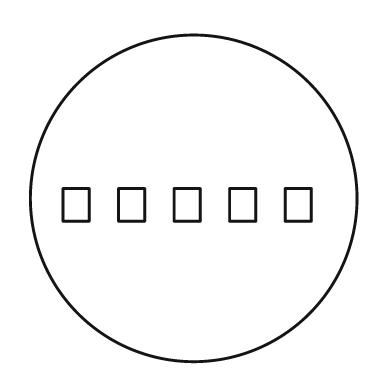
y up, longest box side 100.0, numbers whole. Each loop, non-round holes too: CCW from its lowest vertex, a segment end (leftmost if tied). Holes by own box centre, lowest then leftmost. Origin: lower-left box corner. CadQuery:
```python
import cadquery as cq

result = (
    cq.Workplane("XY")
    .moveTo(50.0, 50.0)
    .circle(50.0)
    .moveTo(10.0, 43.0)
    .lineTo(18.0, 43.0)
    .lineTo(18.0, 53.0)
    .lineTo(10.0, 53.0)
    .close()
    .moveTo(27.0, 43.0)
    .lineTo(35.0, 43.0)
    .lineTo(35.0, 53.0)
    .lineTo(27.0, 53.0)
    .close()
    .moveTo(44.0, 43.0)
    .lineTo(52.0, 43.0)
    .lineTo(52.0, 53.0)
    .lineTo(44.0, 53.0)
    .close()
    .moveTo(61.0, 43.0)
    .lineTo(69.0, 43.0)
    .lineTo(69.0, 53.0)
    .lineTo(61.0, 53.0)
    .close()
    .moveTo(78.0, 43.0)
    .lineTo(86.0, 43.0)
    .lineTo(86.0, 53.0)
    .lineTo(78.0, 53.0)
    .close()
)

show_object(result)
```